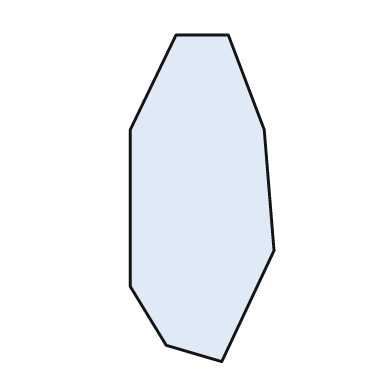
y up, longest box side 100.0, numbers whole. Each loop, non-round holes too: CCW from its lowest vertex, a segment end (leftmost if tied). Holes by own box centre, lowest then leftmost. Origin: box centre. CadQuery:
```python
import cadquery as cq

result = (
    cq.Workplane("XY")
    .moveTo(6.0, -50.0)
    .lineTo(22.0, -16.0)
    .lineTo(19.0, 21.0)
    .lineTo(8.0, 50.0)
    .lineTo(-8.0, 50.0)
    .lineTo(-22.0, 21.0)
    .lineTo(-22.0, -27.0)
    .lineTo(-11.0, -45.0)
    .close()
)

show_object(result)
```